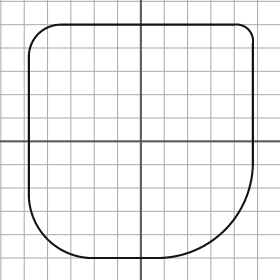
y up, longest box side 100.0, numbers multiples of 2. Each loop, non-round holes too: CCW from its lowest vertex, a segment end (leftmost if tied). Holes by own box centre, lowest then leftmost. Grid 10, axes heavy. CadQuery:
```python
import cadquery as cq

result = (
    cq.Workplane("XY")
    .moveTo(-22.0, -50.0)
    .lineTo(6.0, -50.0)
    .threePointArc((36.0, -38.0), (48.0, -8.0))
    .lineTo(48.0, 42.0)
    .threePointArc((46.0, 48.0), (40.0, 50.0))
    .lineTo(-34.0, 50.0)
    .threePointArc((-44.0, 46.0), (-48.0, 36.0))
    .lineTo(-48.0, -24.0)
    .threePointArc((-40.0, -42.0), (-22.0, -50.0))
    .close()
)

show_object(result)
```